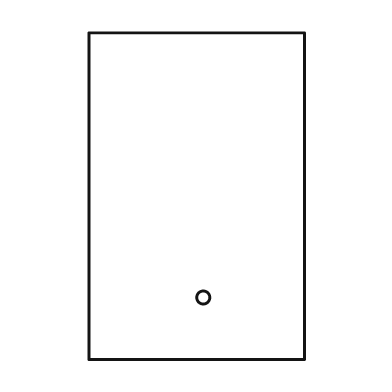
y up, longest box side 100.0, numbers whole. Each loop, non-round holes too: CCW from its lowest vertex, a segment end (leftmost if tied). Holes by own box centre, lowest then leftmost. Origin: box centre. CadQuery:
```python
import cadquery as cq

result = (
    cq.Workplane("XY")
    .moveTo(-33.0, -50.0)
    .lineTo(33.0, -50.0)
    .lineTo(33.0, 50.0)
    .lineTo(-33.0, 50.0)
    .close()
    .moveTo(2.0, -31.0)
    .circle(2.0)
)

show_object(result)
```